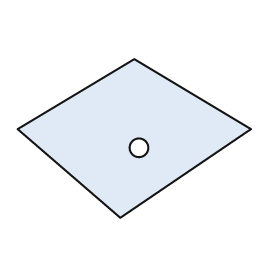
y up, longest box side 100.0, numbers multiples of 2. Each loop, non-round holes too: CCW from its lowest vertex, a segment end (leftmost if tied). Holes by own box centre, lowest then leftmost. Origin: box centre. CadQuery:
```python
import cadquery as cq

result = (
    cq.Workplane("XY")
    .moveTo(-6.0, -34.0)
    .lineTo(50.0, 4.0)
    .lineTo(0.0, 34.0)
    .lineTo(-50.0, 4.0)
    .close()
    .moveTo(2.0, -4.0)
    .circle(4.0)
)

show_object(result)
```